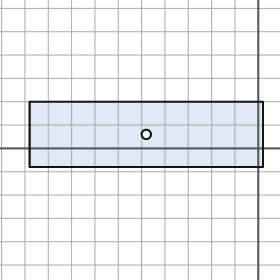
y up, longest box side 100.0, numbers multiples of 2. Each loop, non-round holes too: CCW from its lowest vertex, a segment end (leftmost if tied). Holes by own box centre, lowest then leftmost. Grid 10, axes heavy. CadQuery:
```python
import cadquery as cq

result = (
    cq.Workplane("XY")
    .moveTo(-98.0, -8.0)
    .lineTo(2.0, -8.0)
    .lineTo(2.0, 20.0)
    .lineTo(-98.0, 20.0)
    .close()
    .moveTo(-48.0, 6.0)
    .circle(2.0)
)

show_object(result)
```